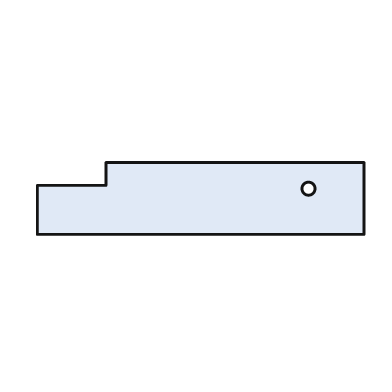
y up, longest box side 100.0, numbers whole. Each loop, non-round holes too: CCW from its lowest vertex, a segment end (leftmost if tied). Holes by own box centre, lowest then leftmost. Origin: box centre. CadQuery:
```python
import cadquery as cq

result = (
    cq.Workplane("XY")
    .moveTo(-50.0, -11.0)
    .lineTo(50.0, -11.0)
    .lineTo(50.0, 11.0)
    .lineTo(-29.0, 11.0)
    .lineTo(-29.0, 4.0)
    .lineTo(-50.0, 4.0)
    .close()
    .moveTo(33.0, 3.0)
    .circle(2.0)
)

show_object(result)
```